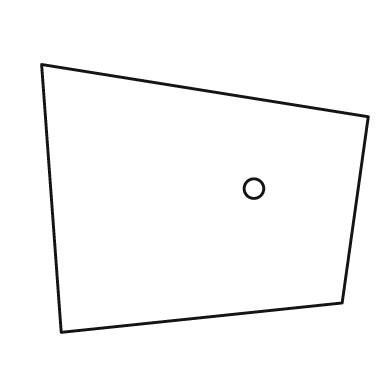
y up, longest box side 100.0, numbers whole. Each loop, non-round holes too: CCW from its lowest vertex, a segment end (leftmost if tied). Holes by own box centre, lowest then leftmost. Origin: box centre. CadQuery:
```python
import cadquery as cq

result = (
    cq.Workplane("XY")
    .moveTo(-44.0, -41.0)
    .lineTo(42.0, -32.0)
    .lineTo(50.0, 25.0)
    .lineTo(-50.0, 41.0)
    .close()
    .moveTo(15.0, 3.0)
    .circle(3.0)
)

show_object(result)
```